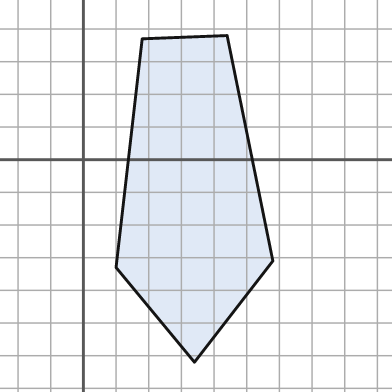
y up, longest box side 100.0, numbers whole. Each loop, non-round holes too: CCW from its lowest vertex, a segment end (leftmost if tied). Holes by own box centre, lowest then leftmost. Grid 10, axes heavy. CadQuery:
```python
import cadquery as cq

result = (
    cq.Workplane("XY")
    .moveTo(34.0, -62.0)
    .lineTo(58.0, -31.0)
    .lineTo(44.0, 38.0)
    .lineTo(18.0, 37.0)
    .lineTo(10.0, -33.0)
    .close()
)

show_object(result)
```